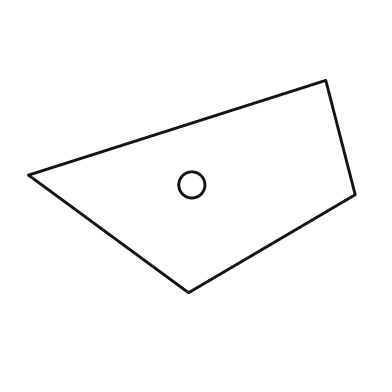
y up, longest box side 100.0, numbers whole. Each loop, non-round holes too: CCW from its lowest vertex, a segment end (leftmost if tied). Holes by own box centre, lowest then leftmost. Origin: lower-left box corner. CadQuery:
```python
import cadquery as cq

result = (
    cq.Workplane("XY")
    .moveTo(49.0, 0.0)
    .lineTo(100.0, 30.0)
    .lineTo(91.0, 65.0)
    .lineTo(0.0, 36.0)
    .close()
    .moveTo(50.0, 33.0)
    .circle(4.0)
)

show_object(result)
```